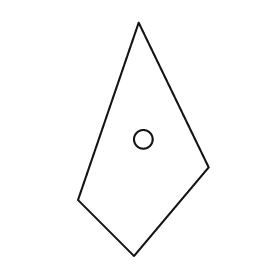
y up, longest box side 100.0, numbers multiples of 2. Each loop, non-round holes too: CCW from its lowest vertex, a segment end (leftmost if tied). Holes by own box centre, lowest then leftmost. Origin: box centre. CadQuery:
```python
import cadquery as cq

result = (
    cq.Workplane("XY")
    .moveTo(-4.0, -50.0)
    .lineTo(28.0, -12.0)
    .lineTo(-2.0, 50.0)
    .lineTo(-28.0, -26.0)
    .close()
    .moveTo(0.0, 0.0)
    .circle(4.0)
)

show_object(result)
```